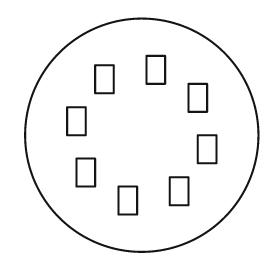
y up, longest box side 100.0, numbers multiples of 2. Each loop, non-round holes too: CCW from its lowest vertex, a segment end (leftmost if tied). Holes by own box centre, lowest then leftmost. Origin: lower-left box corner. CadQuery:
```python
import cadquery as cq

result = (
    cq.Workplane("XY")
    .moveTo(50.0, 50.0)
    .circle(50.0)
    .moveTo(40.0, 16.0)
    .lineTo(48.0, 16.0)
    .lineTo(48.0, 28.0)
    .lineTo(40.0, 28.0)
    .close()
    .moveTo(62.0, 20.0)
    .lineTo(70.0, 20.0)
    .lineTo(70.0, 32.0)
    .lineTo(62.0, 32.0)
    .close()
    .moveTo(22.0, 28.0)
    .lineTo(30.0, 28.0)
    .lineTo(30.0, 40.0)
    .lineTo(22.0, 40.0)
    .close()
    .moveTo(74.0, 38.0)
    .lineTo(82.0, 38.0)
    .lineTo(82.0, 50.0)
    .lineTo(74.0, 50.0)
    .close()
    .moveTo(18.0, 50.0)
    .lineTo(26.0, 50.0)
    .lineTo(26.0, 62.0)
    .lineTo(18.0, 62.0)
    .close()
    .moveTo(70.0, 60.0)
    .lineTo(78.0, 60.0)
    .lineTo(78.0, 72.0)
    .lineTo(70.0, 72.0)
    .close()
    .moveTo(30.0, 68.0)
    .lineTo(38.0, 68.0)
    .lineTo(38.0, 80.0)
    .lineTo(30.0, 80.0)
    .close()
    .moveTo(52.0, 72.0)
    .lineTo(60.0, 72.0)
    .lineTo(60.0, 84.0)
    .lineTo(52.0, 84.0)
    .close()
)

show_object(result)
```